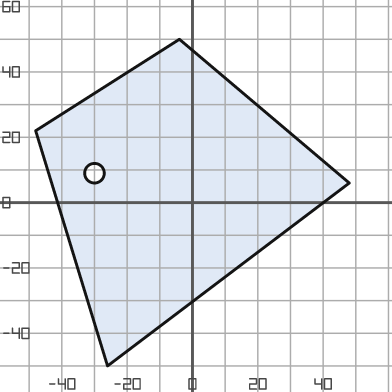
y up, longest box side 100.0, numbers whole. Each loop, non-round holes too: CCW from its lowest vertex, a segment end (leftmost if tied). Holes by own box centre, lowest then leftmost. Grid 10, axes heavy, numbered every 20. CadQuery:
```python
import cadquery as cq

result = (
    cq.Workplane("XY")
    .moveTo(-26.0, -50.0)
    .lineTo(48.0, 6.0)
    .lineTo(-4.0, 50.0)
    .lineTo(-48.0, 22.0)
    .close()
    .moveTo(-30.0, 9.0)
    .circle(3.0)
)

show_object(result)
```